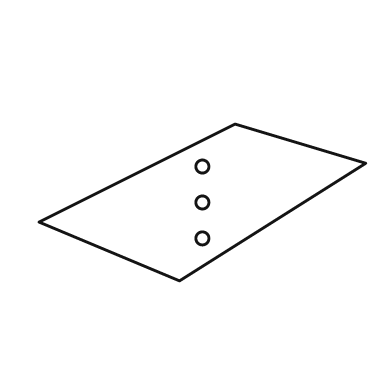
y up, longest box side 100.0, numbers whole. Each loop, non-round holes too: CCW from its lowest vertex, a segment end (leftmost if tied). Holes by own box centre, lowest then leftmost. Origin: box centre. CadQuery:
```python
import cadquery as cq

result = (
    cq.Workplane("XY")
    .moveTo(-7.0, -24.0)
    .lineTo(50.0, 12.0)
    .lineTo(10.0, 24.0)
    .lineTo(-50.0, -6.0)
    .close()
    .moveTo(0.0, -11.0)
    .circle(2.0)
    .moveTo(0.0, 0.0)
    .circle(2.0)
    .moveTo(0.0, 11.0)
    .circle(2.0)
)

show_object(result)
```